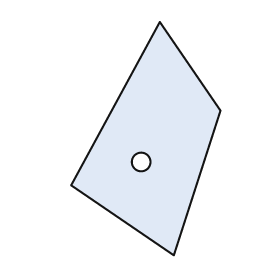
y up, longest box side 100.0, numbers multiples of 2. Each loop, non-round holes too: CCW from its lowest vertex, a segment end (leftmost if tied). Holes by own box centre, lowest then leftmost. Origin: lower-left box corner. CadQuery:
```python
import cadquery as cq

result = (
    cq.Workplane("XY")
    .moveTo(44.0, 0.0)
    .lineTo(64.0, 62.0)
    .lineTo(38.0, 100.0)
    .lineTo(0.0, 30.0)
    .close()
    .moveTo(30.0, 40.0)
    .circle(4.0)
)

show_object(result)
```